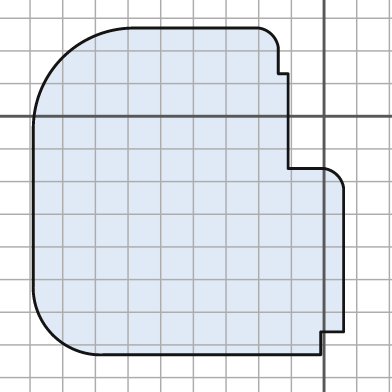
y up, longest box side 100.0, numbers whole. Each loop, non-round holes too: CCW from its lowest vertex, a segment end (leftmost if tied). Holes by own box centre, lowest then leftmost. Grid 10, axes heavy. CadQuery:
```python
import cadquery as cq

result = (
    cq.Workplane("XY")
    .moveTo(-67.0, -73.0)
    .lineTo(-1.0, -73.0)
    .lineTo(-1.0, -66.0)
    .lineTo(6.0, -66.0)
    .lineTo(6.0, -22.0)
    .threePointArc((4.0, -18.0), (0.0, -16.0))
    .lineTo(-11.0, -16.0)
    .lineTo(-11.0, 13.0)
    .lineTo(-14.0, 13.0)
    .lineTo(-14.0, 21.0)
    .threePointArc((-16.0, 25.0), (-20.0, 27.0))
    .lineTo(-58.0, 27.0)
    .threePointArc((-80.0, 18.0), (-89.0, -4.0))
    .lineTo(-89.0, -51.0)
    .threePointArc((-83.0, -67.0), (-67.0, -73.0))
    .close()
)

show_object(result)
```